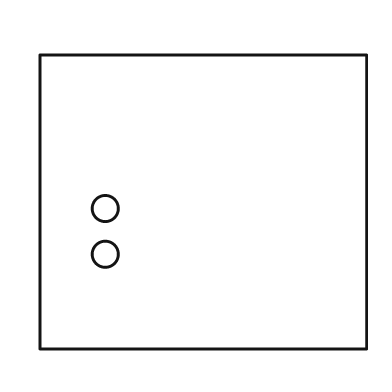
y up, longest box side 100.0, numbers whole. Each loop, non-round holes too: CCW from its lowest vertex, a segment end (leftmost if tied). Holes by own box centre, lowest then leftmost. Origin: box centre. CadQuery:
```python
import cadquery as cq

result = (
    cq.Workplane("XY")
    .moveTo(-50.0, -45.0)
    .lineTo(50.0, -45.0)
    .lineTo(50.0, 45.0)
    .lineTo(-50.0, 45.0)
    .close()
    .moveTo(-30.0, -16.0)
    .circle(4.0)
    .moveTo(-30.0, -2.0)
    .circle(4.0)
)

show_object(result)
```